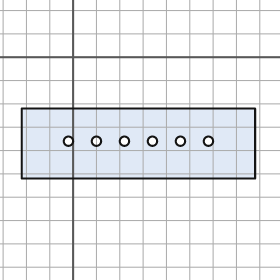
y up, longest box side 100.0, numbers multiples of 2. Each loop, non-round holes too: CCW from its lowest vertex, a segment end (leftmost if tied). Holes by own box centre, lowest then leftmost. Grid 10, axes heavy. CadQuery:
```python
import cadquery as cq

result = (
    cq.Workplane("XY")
    .moveTo(-22.0, -52.0)
    .lineTo(78.0, -52.0)
    .lineTo(78.0, -22.0)
    .lineTo(-22.0, -22.0)
    .close()
    .moveTo(-2.0, -36.0)
    .circle(2.0)
    .moveTo(10.0, -36.0)
    .circle(2.0)
    .moveTo(22.0, -36.0)
    .circle(2.0)
    .moveTo(34.0, -36.0)
    .circle(2.0)
    .moveTo(46.0, -36.0)
    .circle(2.0)
    .moveTo(58.0, -36.0)
    .circle(2.0)
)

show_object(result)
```